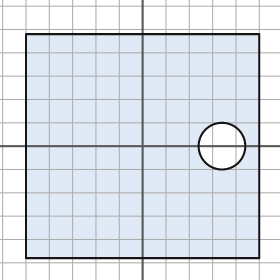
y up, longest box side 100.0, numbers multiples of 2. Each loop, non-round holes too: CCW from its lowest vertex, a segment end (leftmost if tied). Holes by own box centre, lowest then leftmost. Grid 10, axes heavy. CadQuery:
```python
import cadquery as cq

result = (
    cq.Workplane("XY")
    .moveTo(-50.0, -48.0)
    .lineTo(50.0, -48.0)
    .lineTo(50.0, 48.0)
    .lineTo(-50.0, 48.0)
    .close()
    .moveTo(34.0, 0.0)
    .circle(10.0)
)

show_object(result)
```